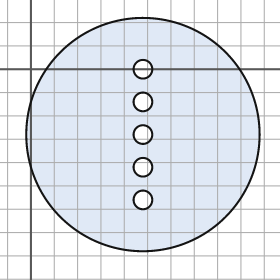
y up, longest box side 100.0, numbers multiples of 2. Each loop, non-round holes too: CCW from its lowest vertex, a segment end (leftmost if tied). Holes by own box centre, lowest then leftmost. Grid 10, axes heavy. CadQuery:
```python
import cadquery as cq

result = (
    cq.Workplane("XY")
    .moveTo(48.0, -28.0)
    .circle(50.0)
    .moveTo(48.0, -56.0)
    .circle(4.0)
    .moveTo(48.0, -42.0)
    .circle(4.0)
    .moveTo(48.0, -28.0)
    .circle(4.0)
    .moveTo(48.0, -14.0)
    .circle(4.0)
    .moveTo(48.0, 0.0)
    .circle(4.0)
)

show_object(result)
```